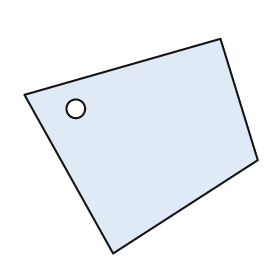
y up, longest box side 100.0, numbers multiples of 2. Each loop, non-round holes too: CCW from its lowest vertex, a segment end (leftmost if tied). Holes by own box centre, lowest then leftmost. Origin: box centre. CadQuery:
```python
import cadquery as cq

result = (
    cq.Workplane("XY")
    .moveTo(-12.0, -46.0)
    .lineTo(50.0, -6.0)
    .lineTo(34.0, 46.0)
    .lineTo(-50.0, 22.0)
    .close()
    .moveTo(-28.0, 16.0)
    .circle(4.0)
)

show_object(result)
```